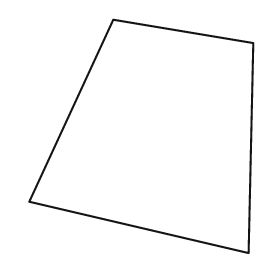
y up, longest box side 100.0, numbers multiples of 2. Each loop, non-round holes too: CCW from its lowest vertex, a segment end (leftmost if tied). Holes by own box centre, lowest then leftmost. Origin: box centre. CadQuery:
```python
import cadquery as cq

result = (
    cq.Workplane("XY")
    .moveTo(46.0, -50.0)
    .lineTo(48.0, 40.0)
    .lineTo(-12.0, 50.0)
    .lineTo(-48.0, -28.0)
    .close()
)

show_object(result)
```